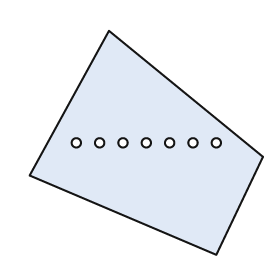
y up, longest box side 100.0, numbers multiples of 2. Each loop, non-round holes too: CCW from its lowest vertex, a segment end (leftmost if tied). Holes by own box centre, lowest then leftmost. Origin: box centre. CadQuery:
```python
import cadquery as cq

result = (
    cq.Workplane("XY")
    .moveTo(30.0, -48.0)
    .lineTo(50.0, -6.0)
    .lineTo(-16.0, 48.0)
    .lineTo(-50.0, -14.0)
    .close()
    .moveTo(-30.0, 0.0)
    .circle(2.0)
    .moveTo(-20.0, 0.0)
    .circle(2.0)
    .moveTo(-10.0, 0.0)
    .circle(2.0)
    .moveTo(0.0, 0.0)
    .circle(2.0)
    .moveTo(10.0, 0.0)
    .circle(2.0)
    .moveTo(20.0, 0.0)
    .circle(2.0)
    .moveTo(30.0, 0.0)
    .circle(2.0)
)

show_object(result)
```